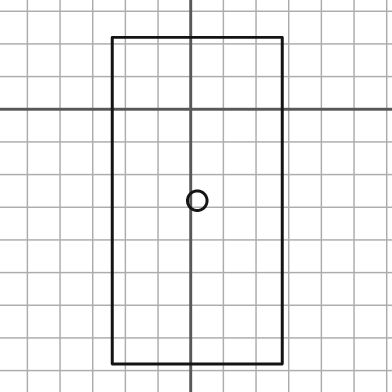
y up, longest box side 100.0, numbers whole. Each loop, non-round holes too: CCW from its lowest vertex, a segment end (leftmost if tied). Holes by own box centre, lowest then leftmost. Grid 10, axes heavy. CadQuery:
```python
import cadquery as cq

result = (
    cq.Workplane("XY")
    .moveTo(-24.0, -78.0)
    .lineTo(28.0, -78.0)
    .lineTo(28.0, 22.0)
    .lineTo(-24.0, 22.0)
    .close()
    .moveTo(2.0, -28.0)
    .circle(3.0)
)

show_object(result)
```